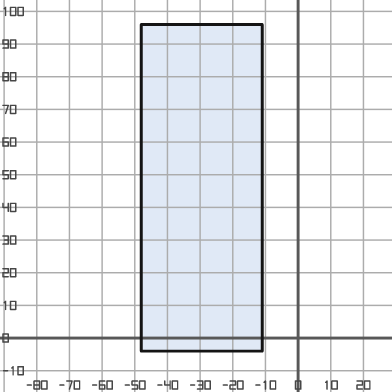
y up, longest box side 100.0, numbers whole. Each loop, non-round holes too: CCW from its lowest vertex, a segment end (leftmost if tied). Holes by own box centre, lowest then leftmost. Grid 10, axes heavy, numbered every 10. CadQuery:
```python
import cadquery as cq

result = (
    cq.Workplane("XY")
    .moveTo(-48.0, -4.0)
    .lineTo(-11.0, -4.0)
    .lineTo(-11.0, 96.0)
    .lineTo(-48.0, 96.0)
    .close()
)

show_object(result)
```